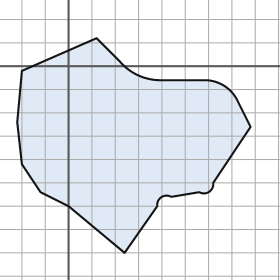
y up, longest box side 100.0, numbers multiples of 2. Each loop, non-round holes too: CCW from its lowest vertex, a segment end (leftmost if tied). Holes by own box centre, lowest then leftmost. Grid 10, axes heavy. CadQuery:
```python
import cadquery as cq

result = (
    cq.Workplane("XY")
    .moveTo(24.0, -80.0)
    .lineTo(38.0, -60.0)
    .threePointArc((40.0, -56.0), (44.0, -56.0))
    .lineTo(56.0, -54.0)
    .threePointArc((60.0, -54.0), (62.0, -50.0))
    .lineTo(78.0, -26.0)
    .lineTo(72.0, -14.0)
    .threePointArc((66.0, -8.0), (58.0, -6.0))
    .lineTo(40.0, -6.0)
    .threePointArc((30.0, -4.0), (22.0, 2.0))
    .lineTo(12.0, 12.0)
    .lineTo(-20.0, -2.0)
    .lineTo(-22.0, -24.0)
    .lineTo(-20.0, -42.0)
    .lineTo(-12.0, -54.0)
    .lineTo(0.0, -60.0)
    .close()
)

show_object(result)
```